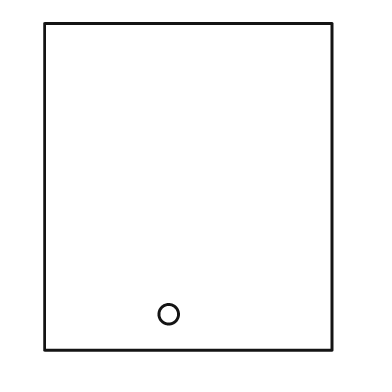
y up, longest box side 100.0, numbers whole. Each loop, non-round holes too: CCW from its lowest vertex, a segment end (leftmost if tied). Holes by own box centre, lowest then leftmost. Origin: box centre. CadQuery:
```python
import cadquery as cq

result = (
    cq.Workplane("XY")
    .moveTo(-44.0, -50.0)
    .lineTo(44.0, -50.0)
    .lineTo(44.0, 50.0)
    .lineTo(-44.0, 50.0)
    .close()
    .moveTo(-6.0, -39.0)
    .circle(3.0)
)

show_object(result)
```